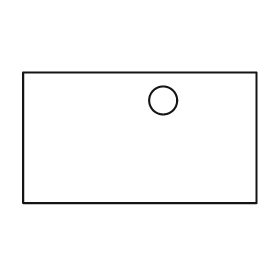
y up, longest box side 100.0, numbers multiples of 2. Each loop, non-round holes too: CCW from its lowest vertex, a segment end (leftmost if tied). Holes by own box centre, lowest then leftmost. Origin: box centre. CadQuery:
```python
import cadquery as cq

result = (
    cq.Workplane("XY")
    .moveTo(-50.0, -28.0)
    .lineTo(50.0, -28.0)
    .lineTo(50.0, 28.0)
    .lineTo(-50.0, 28.0)
    .close()
    .moveTo(10.0, 16.0)
    .circle(6.0)
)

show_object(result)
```